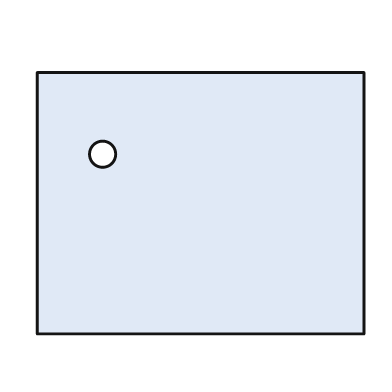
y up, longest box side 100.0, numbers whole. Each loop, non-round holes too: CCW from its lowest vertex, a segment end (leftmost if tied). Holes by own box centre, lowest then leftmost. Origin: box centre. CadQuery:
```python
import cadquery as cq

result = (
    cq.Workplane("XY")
    .moveTo(-50.0, -40.0)
    .lineTo(50.0, -40.0)
    .lineTo(50.0, 40.0)
    .lineTo(-50.0, 40.0)
    .close()
    .moveTo(-30.0, 15.0)
    .circle(4.0)
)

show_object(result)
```